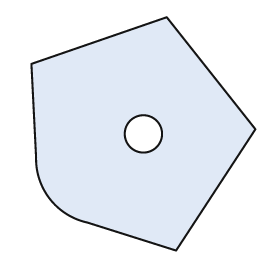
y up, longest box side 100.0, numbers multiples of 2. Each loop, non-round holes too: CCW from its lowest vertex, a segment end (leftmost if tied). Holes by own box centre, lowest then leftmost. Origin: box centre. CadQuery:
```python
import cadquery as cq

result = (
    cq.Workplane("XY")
    .moveTo(14.0, -50.0)
    .lineTo(48.0, 2.0)
    .lineTo(10.0, 50.0)
    .lineTo(-48.0, 30.0)
    .lineTo(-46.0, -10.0)
    .threePointArc((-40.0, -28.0), (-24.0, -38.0))
    .close()
    .moveTo(0.0, 0.0)
    .circle(8.0)
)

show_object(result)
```